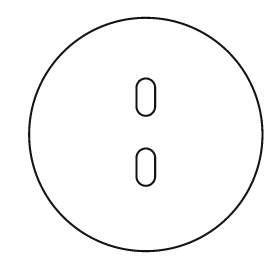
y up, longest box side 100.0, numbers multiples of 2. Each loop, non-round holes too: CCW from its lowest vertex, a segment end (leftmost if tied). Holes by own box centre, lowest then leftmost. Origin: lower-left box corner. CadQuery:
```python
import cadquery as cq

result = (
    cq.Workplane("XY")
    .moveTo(50.0, 50.0)
    .circle(50.0)
    .moveTo(46.0, 32.0)
    .threePointArc((50.0, 28.0), (54.0, 32.0))
    .lineTo(54.0, 40.0)
    .threePointArc((50.0, 44.0), (46.0, 40.0))
    .close()
    .moveTo(46.0, 62.0)
    .threePointArc((50.0, 58.0), (54.0, 62.0))
    .lineTo(54.0, 70.0)
    .threePointArc((50.0, 74.0), (46.0, 70.0))
    .close()
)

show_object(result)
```